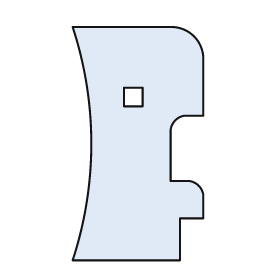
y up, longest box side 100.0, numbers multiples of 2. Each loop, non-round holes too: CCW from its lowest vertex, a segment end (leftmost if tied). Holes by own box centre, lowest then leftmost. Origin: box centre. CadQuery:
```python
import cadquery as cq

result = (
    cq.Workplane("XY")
    .moveTo(-28.0, -50.0)
    .lineTo(18.0, -50.0)
    .lineTo(18.0, -32.0)
    .lineTo(28.0, -32.0)
    .lineTo(28.0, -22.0)
    .threePointArc((26.0, -18.0), (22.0, -16.0))
    .lineTo(14.0, -16.0)
    .lineTo(14.0, 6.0)
    .threePointArc((16.0, 10.0), (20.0, 12.0))
    .lineTo(28.0, 12.0)
    .lineTo(28.0, 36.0)
    .threePointArc((24.0, 46.0), (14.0, 50.0))
    .lineTo(-28.0, 50.0)
    .threePointArc((-20.0, 0.0), (-28.0, -50.0))
    .close()
    .moveTo(-6.0, 16.0)
    .lineTo(2.0, 16.0)
    .lineTo(2.0, 24.0)
    .lineTo(-6.0, 24.0)
    .close()
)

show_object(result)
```